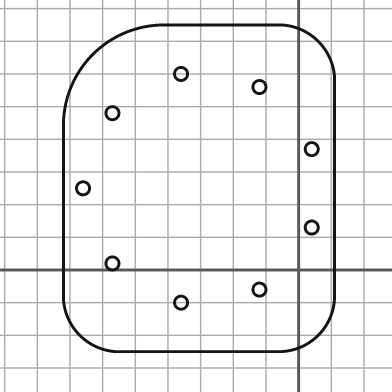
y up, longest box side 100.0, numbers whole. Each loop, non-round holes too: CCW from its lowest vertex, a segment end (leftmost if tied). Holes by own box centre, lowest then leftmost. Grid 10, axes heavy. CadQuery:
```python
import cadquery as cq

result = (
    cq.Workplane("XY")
    .moveTo(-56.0, -25.0)
    .lineTo(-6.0, -25.0)
    .threePointArc((6.0, -20.0), (11.0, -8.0))
    .lineTo(11.0, 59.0)
    .threePointArc((6.0, 70.0), (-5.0, 75.0))
    .lineTo(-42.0, 75.0)
    .threePointArc((-63.0, 66.0), (-72.0, 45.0))
    .lineTo(-72.0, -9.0)
    .threePointArc((-67.0, -20.0), (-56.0, -25.0))
    .close()
    .moveTo(-36.0, -10.0)
    .circle(2.0)
    .moveTo(-12.0, -6.0)
    .circle(2.0)
    .moveTo(-57.0, 2.0)
    .circle(2.0)
    .moveTo(4.0, 13.0)
    .circle(2.0)
    .moveTo(-66.0, 25.0)
    .circle(2.0)
    .moveTo(4.0, 37.0)
    .circle(2.0)
    .moveTo(-57.0, 48.0)
    .circle(2.0)
    .moveTo(-12.0, 56.0)
    .circle(2.0)
    .moveTo(-36.0, 60.0)
    .circle(2.0)
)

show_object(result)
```